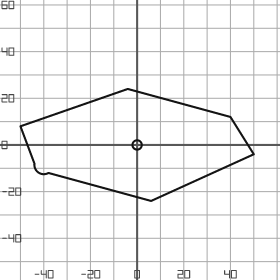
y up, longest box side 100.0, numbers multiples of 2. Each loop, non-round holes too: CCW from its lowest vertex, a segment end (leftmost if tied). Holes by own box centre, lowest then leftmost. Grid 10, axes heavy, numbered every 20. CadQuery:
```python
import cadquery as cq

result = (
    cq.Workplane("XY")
    .moveTo(6.0, -24.0)
    .lineTo(50.0, -4.0)
    .lineTo(40.0, 12.0)
    .lineTo(-4.0, 24.0)
    .lineTo(-50.0, 8.0)
    .lineTo(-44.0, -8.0)
    .threePointArc((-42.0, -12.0), (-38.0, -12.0))
    .close()
    .moveTo(0.0, 0.0)
    .circle(2.0)
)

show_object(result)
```